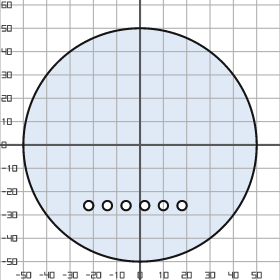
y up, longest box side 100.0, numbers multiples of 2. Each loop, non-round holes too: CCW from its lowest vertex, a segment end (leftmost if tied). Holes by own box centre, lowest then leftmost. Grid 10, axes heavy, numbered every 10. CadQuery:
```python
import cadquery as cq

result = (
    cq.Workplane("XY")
    .moveTo(0.0, 0.0)
    .circle(50.0)
    .moveTo(-22.0, -26.0)
    .circle(2.0)
    .moveTo(-14.0, -26.0)
    .circle(2.0)
    .moveTo(-6.0, -26.0)
    .circle(2.0)
    .moveTo(2.0, -26.0)
    .circle(2.0)
    .moveTo(10.0, -26.0)
    .circle(2.0)
    .moveTo(18.0, -26.0)
    .circle(2.0)
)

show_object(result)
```